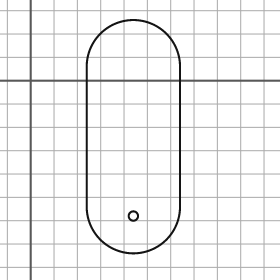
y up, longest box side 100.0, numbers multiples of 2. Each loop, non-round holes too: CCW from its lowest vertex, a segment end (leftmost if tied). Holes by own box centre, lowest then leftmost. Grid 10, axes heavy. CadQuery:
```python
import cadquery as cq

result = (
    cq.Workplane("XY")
    .moveTo(24.0, -54.0)
    .threePointArc((44.0, -74.0), (64.0, -54.0))
    .lineTo(64.0, 6.0)
    .threePointArc((44.0, 26.0), (24.0, 6.0))
    .close()
    .moveTo(44.0, -58.0)
    .circle(2.0)
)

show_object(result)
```